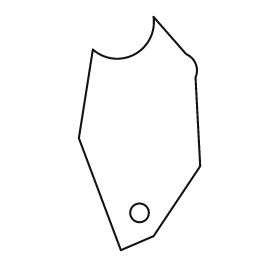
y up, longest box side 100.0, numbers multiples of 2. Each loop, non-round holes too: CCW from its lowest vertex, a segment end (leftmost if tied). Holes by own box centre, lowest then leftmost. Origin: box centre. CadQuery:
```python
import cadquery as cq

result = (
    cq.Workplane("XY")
    .moveTo(-8.0, -50.0)
    .lineTo(6.0, -44.0)
    .lineTo(26.0, -14.0)
    .lineTo(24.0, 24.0)
    .threePointArc((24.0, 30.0), (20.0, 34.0))
    .lineTo(6.0, 50.0)
    .threePointArc((-2.0, 34.0), (-20.0, 36.0))
    .lineTo(-26.0, -2.0)
    .close()
    .moveTo(0.0, -34.0)
    .circle(4.0)
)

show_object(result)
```